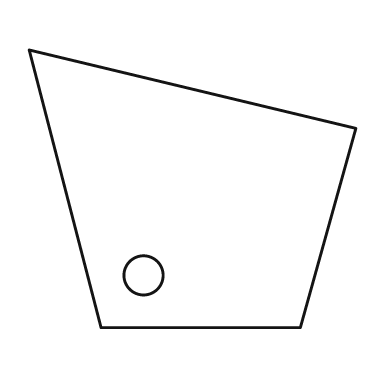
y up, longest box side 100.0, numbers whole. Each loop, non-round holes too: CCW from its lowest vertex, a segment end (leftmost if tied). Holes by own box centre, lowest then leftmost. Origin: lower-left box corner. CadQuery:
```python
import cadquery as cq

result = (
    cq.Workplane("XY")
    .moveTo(22.0, 0.0)
    .lineTo(83.0, 0.0)
    .lineTo(100.0, 61.0)
    .lineTo(0.0, 85.0)
    .close()
    .moveTo(35.0, 16.0)
    .circle(6.0)
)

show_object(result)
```